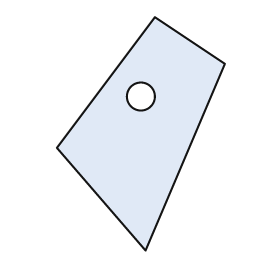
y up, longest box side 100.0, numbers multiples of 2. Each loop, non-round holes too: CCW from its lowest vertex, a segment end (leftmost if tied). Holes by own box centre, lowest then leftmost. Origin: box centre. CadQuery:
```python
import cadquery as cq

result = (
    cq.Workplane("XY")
    .moveTo(2.0, -50.0)
    .lineTo(36.0, 30.0)
    .lineTo(6.0, 50.0)
    .lineTo(-36.0, -6.0)
    .close()
    .moveTo(0.0, 16.0)
    .circle(6.0)
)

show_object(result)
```